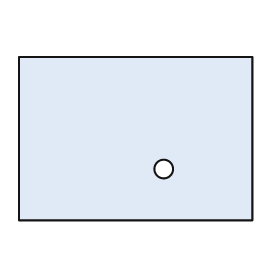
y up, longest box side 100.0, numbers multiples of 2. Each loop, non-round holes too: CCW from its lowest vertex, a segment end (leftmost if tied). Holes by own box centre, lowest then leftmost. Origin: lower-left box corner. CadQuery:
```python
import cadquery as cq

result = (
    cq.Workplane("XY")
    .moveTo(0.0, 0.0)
    .lineTo(100.0, 0.0)
    .lineTo(100.0, 70.0)
    .lineTo(0.0, 70.0)
    .close()
    .moveTo(62.0, 22.0)
    .circle(4.0)
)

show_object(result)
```